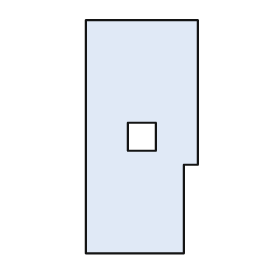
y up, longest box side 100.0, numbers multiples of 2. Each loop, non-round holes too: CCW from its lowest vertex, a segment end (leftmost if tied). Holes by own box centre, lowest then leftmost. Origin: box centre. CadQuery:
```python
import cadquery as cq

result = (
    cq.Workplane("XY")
    .moveTo(-24.0, -50.0)
    .lineTo(18.0, -50.0)
    .lineTo(18.0, -12.0)
    .lineTo(24.0, -12.0)
    .lineTo(24.0, 50.0)
    .lineTo(-24.0, 50.0)
    .close()
    .moveTo(-6.0, -6.0)
    .lineTo(6.0, -6.0)
    .lineTo(6.0, 6.0)
    .lineTo(-6.0, 6.0)
    .close()
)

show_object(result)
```